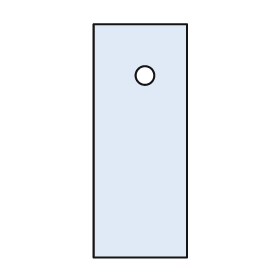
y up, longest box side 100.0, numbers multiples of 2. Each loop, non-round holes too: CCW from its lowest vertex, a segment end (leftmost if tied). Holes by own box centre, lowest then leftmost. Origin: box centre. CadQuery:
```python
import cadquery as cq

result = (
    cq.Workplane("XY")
    .moveTo(-20.0, -50.0)
    .lineTo(20.0, -50.0)
    .lineTo(20.0, 50.0)
    .lineTo(-20.0, 50.0)
    .close()
    .moveTo(2.0, 28.0)
    .circle(4.0)
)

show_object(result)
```